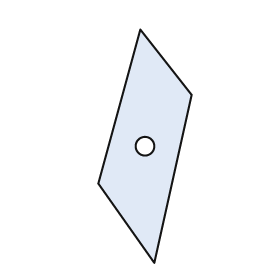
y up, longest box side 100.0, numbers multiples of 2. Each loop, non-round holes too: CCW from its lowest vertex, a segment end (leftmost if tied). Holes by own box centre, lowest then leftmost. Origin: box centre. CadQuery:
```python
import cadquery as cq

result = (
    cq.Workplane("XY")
    .moveTo(4.0, -50.0)
    .lineTo(20.0, 22.0)
    .lineTo(-2.0, 50.0)
    .lineTo(-20.0, -16.0)
    .close()
    .moveTo(0.0, 0.0)
    .circle(4.0)
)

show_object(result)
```